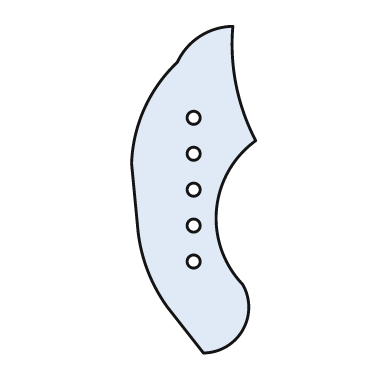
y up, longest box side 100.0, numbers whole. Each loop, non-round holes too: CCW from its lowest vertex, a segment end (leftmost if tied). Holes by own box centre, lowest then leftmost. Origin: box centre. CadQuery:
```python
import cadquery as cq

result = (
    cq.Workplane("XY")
    .moveTo(3.0, -50.0)
    .threePointArc((15.0, -43.0), (15.0, -29.0))
    .threePointArc((7.0, -6.0), (19.0, 15.0))
    .threePointArc((13.0, 32.0), (12.0, 50.0))
    .threePointArc((2.0, 47.0), (-5.0, 39.0))
    .threePointArc((-15.0, 25.0), (-19.0, 8.0))
    .lineTo(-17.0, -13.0)
    .threePointArc((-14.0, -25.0), (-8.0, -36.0))
    .close()
    .moveTo(0.0, -22.0)
    .circle(2.0)
    .moveTo(0.0, -11.0)
    .circle(2.0)
    .moveTo(0.0, 0.0)
    .circle(2.0)
    .moveTo(0.0, 11.0)
    .circle(2.0)
    .moveTo(0.0, 22.0)
    .circle(2.0)
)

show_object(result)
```